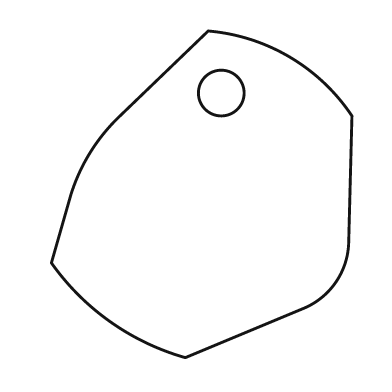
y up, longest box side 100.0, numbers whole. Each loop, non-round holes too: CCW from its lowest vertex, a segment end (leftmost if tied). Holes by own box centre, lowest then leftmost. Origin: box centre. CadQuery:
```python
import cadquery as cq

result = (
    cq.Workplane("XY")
    .moveTo(-5.0, -50.0)
    .lineTo(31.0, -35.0)
    .threePointArc((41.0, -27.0), (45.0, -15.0))
    .lineTo(46.0, 24.0)
    .threePointArc((27.0, 42.0), (2.0, 50.0))
    .lineTo(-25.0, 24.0)
    .threePointArc((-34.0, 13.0), (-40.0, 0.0))
    .lineTo(-46.0, -21.0)
    .threePointArc((-28.0, -39.0), (-5.0, -50.0))
    .close()
    .moveTo(6.0, 31.0)
    .circle(7.0)
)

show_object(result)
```